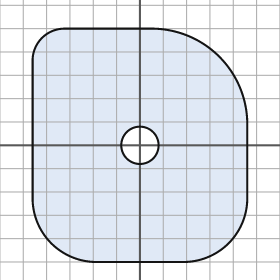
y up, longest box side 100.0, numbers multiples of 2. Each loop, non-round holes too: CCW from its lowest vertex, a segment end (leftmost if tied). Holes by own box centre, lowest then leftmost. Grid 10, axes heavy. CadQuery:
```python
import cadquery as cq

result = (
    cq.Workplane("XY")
    .moveTo(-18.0, -50.0)
    .lineTo(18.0, -50.0)
    .threePointArc((38.0, -42.0), (46.0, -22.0))
    .lineTo(46.0, 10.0)
    .threePointArc((34.0, 38.0), (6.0, 50.0))
    .lineTo(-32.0, 50.0)
    .threePointArc((-42.0, 46.0), (-46.0, 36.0))
    .lineTo(-46.0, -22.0)
    .threePointArc((-38.0, -42.0), (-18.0, -50.0))
    .close()
    .moveTo(0.0, 0.0)
    .circle(8.0)
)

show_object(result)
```